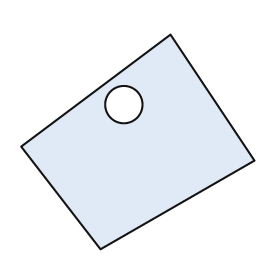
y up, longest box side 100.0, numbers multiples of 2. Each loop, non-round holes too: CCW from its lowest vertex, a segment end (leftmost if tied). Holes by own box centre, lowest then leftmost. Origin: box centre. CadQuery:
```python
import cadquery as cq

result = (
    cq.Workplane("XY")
    .moveTo(-16.0, -46.0)
    .lineTo(50.0, -8.0)
    .lineTo(14.0, 46.0)
    .lineTo(-50.0, -2.0)
    .close()
    .moveTo(-6.0, 16.0)
    .circle(8.0)
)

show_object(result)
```